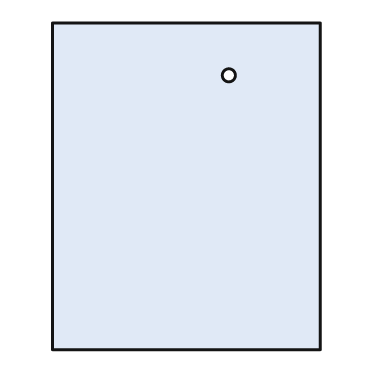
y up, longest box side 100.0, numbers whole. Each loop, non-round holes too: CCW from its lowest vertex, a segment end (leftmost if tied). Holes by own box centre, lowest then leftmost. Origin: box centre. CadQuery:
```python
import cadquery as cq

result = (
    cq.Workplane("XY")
    .moveTo(-41.0, -50.0)
    .lineTo(41.0, -50.0)
    .lineTo(41.0, 50.0)
    .lineTo(-41.0, 50.0)
    .close()
    .moveTo(13.0, 34.0)
    .circle(2.0)
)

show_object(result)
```